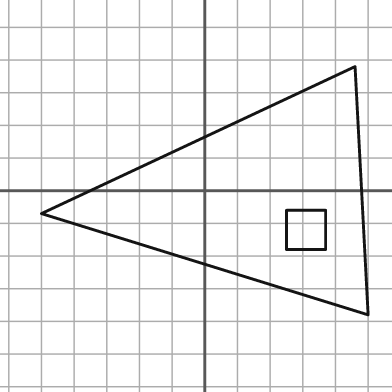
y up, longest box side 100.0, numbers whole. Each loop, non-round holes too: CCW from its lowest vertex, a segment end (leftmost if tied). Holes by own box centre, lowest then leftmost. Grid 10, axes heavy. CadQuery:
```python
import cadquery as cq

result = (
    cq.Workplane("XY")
    .moveTo(50.0, -38.0)
    .lineTo(46.0, 38.0)
    .lineTo(-50.0, -7.0)
    .close()
    .moveTo(25.0, -18.0)
    .lineTo(37.0, -18.0)
    .lineTo(37.0, -6.0)
    .lineTo(25.0, -6.0)
    .close()
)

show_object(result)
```